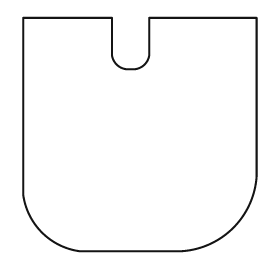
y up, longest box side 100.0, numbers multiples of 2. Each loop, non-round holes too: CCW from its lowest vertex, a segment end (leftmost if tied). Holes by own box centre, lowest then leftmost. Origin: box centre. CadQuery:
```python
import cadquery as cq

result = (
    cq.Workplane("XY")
    .moveTo(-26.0, -50.0)
    .lineTo(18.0, -50.0)
    .threePointArc((40.0, -40.0), (50.0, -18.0))
    .lineTo(50.0, 50.0)
    .lineTo(4.0, 50.0)
    .lineTo(4.0, 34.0)
    .threePointArc((2.0, 30.0), (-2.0, 28.0))
    .lineTo(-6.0, 28.0)
    .threePointArc((-10.0, 30.0), (-12.0, 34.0))
    .lineTo(-12.0, 50.0)
    .lineTo(-50.0, 50.0)
    .lineTo(-50.0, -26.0)
    .threePointArc((-42.0, -42.0), (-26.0, -50.0))
    .close()
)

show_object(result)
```